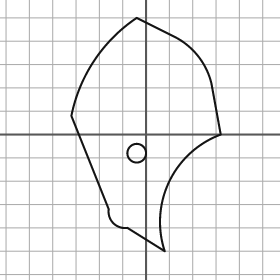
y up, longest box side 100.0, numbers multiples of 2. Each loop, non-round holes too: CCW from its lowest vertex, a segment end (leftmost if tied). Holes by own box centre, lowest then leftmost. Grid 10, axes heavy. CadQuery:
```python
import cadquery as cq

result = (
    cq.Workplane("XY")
    .moveTo(8.0, -50.0)
    .threePointArc((10.0, -20.0), (32.0, 0.0))
    .lineTo(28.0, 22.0)
    .threePointArc((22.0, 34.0), (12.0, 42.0))
    .lineTo(-4.0, 50.0)
    .threePointArc((-22.0, 32.0), (-32.0, 8.0))
    .lineTo(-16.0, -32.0)
    .threePointArc((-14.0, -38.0), (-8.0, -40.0))
    .close()
    .moveTo(-4.0, -8.0)
    .circle(4.0)
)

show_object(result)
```